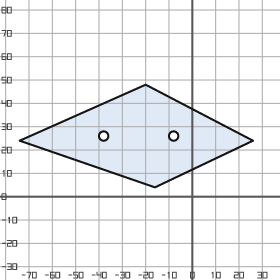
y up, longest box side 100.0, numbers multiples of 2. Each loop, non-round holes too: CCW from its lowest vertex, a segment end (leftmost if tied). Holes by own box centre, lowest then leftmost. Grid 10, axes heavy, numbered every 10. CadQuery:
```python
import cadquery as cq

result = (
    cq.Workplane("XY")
    .moveTo(-16.0, 4.0)
    .lineTo(26.0, 24.0)
    .lineTo(-20.0, 48.0)
    .lineTo(-74.0, 24.0)
    .close()
    .moveTo(-38.0, 26.0)
    .circle(2.0)
    .moveTo(-8.0, 26.0)
    .circle(2.0)
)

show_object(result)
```